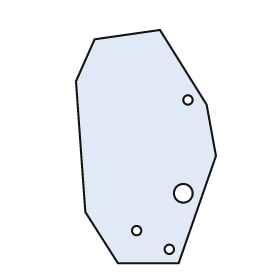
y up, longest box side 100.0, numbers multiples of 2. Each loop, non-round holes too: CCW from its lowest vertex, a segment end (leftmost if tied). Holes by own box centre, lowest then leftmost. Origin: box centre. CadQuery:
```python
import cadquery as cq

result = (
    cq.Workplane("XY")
    .moveTo(-12.0, -50.0)
    .lineTo(14.0, -50.0)
    .lineTo(30.0, -4.0)
    .lineTo(26.0, 18.0)
    .lineTo(6.0, 50.0)
    .lineTo(-22.0, 46.0)
    .lineTo(-30.0, 28.0)
    .lineTo(-26.0, -28.0)
    .close()
    .moveTo(10.0, -44.0)
    .circle(2.0)
    .moveTo(-4.0, -36.0)
    .circle(2.0)
    .moveTo(16.0, -20.0)
    .circle(4.0)
    .moveTo(18.0, 20.0)
    .circle(2.0)
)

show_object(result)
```